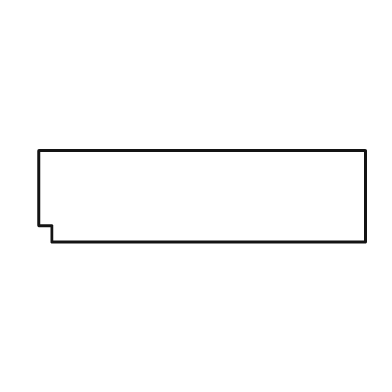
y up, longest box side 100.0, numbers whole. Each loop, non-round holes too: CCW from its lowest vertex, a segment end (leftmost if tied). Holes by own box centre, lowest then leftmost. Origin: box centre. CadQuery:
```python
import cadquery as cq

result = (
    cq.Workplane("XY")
    .moveTo(-46.0, -14.0)
    .lineTo(50.0, -14.0)
    .lineTo(50.0, 14.0)
    .lineTo(-50.0, 14.0)
    .lineTo(-50.0, -9.0)
    .lineTo(-46.0, -9.0)
    .close()
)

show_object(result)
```